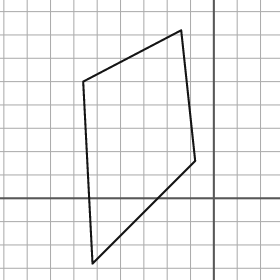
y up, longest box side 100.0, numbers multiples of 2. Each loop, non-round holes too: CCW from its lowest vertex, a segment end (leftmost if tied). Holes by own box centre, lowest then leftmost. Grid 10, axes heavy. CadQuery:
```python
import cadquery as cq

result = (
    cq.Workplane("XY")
    .moveTo(-52.0, -28.0)
    .lineTo(-8.0, 16.0)
    .lineTo(-14.0, 72.0)
    .lineTo(-56.0, 50.0)
    .close()
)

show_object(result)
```